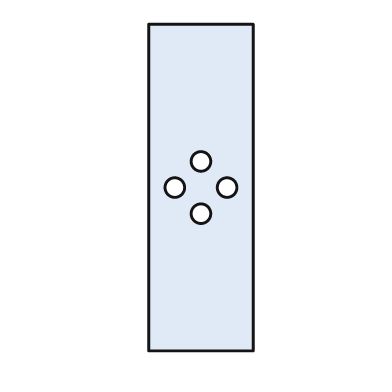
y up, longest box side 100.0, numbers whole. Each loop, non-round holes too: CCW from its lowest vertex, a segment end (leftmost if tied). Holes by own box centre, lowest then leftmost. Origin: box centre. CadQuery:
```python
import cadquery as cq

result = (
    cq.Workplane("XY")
    .moveTo(-16.0, -50.0)
    .lineTo(16.0, -50.0)
    .lineTo(16.0, 50.0)
    .lineTo(-16.0, 50.0)
    .close()
    .moveTo(0.0, -8.0)
    .circle(3.0)
    .moveTo(-8.0, 0.0)
    .circle(3.0)
    .moveTo(8.0, 0.0)
    .circle(3.0)
    .moveTo(0.0, 8.0)
    .circle(3.0)
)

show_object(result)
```